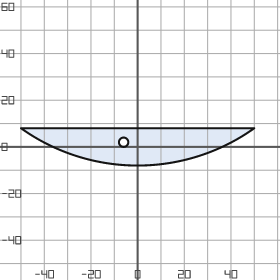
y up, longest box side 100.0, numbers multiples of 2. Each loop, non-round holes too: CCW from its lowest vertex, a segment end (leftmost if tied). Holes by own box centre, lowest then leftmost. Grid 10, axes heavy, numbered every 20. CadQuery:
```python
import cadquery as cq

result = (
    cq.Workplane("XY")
    .moveTo(-50.0, 8.0)
    .threePointArc((0.0, -8.0), (50.0, 8.0))
    .close()
    .moveTo(-6.0, 2.0)
    .circle(2.0)
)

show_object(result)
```